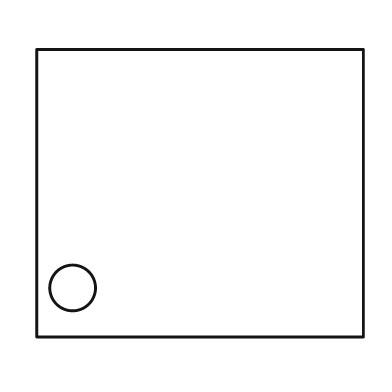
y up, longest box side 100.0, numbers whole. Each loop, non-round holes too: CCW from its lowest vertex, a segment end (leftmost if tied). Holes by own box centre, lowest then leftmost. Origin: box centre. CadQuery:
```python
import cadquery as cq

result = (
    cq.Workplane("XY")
    .moveTo(-50.0, -44.0)
    .lineTo(50.0, -44.0)
    .lineTo(50.0, 44.0)
    .lineTo(-50.0, 44.0)
    .close()
    .moveTo(-39.0, -29.0)
    .circle(7.0)
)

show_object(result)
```